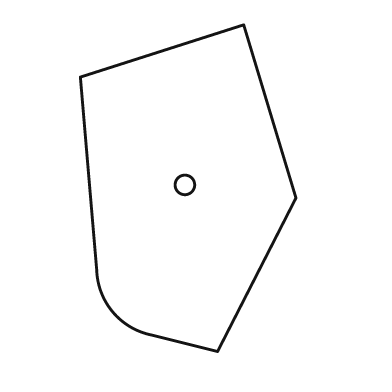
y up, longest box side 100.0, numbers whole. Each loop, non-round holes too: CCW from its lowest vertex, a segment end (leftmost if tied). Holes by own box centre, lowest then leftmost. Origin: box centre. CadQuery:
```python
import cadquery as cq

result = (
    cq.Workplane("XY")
    .moveTo(9.0, -50.0)
    .lineTo(33.0, -3.0)
    .lineTo(17.0, 50.0)
    .lineTo(-33.0, 34.0)
    .lineTo(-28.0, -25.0)
    .threePointArc((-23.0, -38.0), (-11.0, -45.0))
    .close()
    .moveTo(-1.0, 1.0)
    .circle(3.0)
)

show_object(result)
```